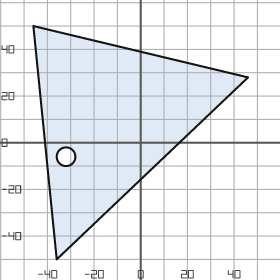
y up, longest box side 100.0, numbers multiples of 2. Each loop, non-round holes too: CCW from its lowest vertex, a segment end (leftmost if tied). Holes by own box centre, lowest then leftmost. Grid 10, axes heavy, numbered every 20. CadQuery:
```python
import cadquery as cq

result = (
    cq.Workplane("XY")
    .moveTo(-36.0, -50.0)
    .lineTo(46.0, 28.0)
    .lineTo(-46.0, 50.0)
    .close()
    .moveTo(-32.0, -6.0)
    .circle(4.0)
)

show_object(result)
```